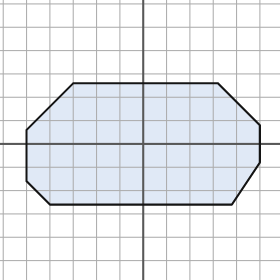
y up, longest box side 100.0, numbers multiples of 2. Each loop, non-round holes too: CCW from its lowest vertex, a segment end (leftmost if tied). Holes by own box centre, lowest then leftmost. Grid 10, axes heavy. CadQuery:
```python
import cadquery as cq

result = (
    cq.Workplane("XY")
    .moveTo(-40.0, -26.0)
    .lineTo(38.0, -26.0)
    .lineTo(50.0, -8.0)
    .lineTo(50.0, 8.0)
    .lineTo(32.0, 26.0)
    .lineTo(-30.0, 26.0)
    .lineTo(-50.0, 6.0)
    .lineTo(-50.0, -16.0)
    .close()
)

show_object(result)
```